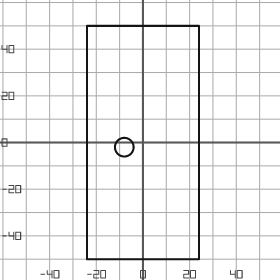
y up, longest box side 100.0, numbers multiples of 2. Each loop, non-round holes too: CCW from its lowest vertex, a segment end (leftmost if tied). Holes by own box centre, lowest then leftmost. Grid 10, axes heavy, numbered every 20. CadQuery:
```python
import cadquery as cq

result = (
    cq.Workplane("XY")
    .moveTo(-24.0, -50.0)
    .lineTo(24.0, -50.0)
    .lineTo(24.0, 50.0)
    .lineTo(-24.0, 50.0)
    .close()
    .moveTo(-8.0, -2.0)
    .circle(4.0)
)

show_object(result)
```